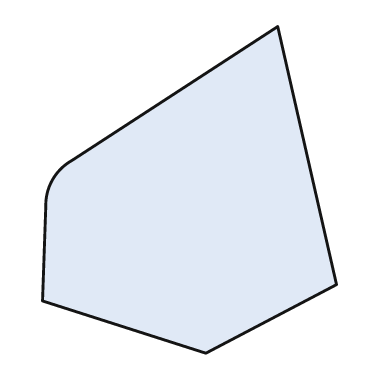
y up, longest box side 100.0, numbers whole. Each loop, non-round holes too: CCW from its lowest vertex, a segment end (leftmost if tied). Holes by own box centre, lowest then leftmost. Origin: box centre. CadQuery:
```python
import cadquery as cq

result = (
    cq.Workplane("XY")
    .moveTo(5.0, -50.0)
    .lineTo(45.0, -29.0)
    .lineTo(27.0, 50.0)
    .lineTo(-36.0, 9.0)
    .threePointArc((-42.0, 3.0), (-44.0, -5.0))
    .lineTo(-45.0, -34.0)
    .close()
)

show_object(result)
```